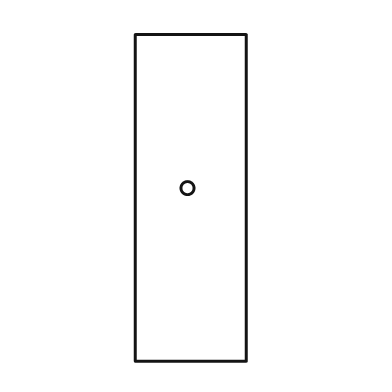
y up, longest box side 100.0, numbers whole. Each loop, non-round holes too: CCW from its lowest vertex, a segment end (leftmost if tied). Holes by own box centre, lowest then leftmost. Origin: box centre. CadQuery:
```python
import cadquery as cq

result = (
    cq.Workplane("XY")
    .moveTo(-17.0, -50.0)
    .lineTo(17.0, -50.0)
    .lineTo(17.0, 50.0)
    .lineTo(-17.0, 50.0)
    .close()
    .moveTo(-1.0, 3.0)
    .circle(2.0)
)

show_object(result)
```